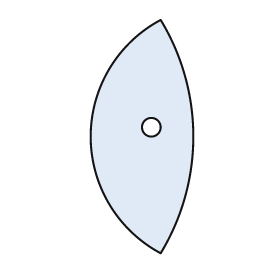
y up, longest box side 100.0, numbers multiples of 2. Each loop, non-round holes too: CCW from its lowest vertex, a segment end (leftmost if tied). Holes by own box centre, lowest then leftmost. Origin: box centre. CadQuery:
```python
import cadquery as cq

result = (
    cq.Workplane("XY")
    .moveTo(8.0, -50.0)
    .threePointArc((22.0, 0.0), (8.0, 50.0))
    .threePointArc((-22.0, 0.0), (8.0, -50.0))
    .close()
    .moveTo(4.0, 4.0)
    .circle(4.0)
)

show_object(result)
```